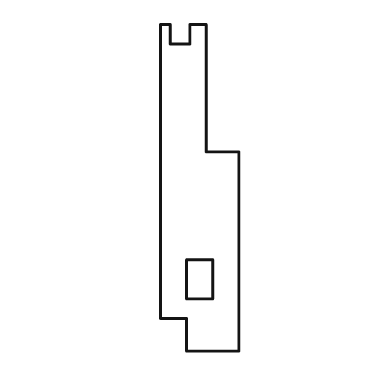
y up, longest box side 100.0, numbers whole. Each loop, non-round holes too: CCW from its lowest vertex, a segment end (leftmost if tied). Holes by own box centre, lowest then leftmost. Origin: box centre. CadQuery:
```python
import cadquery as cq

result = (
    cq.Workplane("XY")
    .moveTo(-4.0, -50.0)
    .lineTo(12.0, -50.0)
    .lineTo(12.0, 11.0)
    .lineTo(2.0, 11.0)
    .lineTo(2.0, 50.0)
    .lineTo(-3.0, 50.0)
    .lineTo(-3.0, 44.0)
    .lineTo(-9.0, 44.0)
    .lineTo(-9.0, 50.0)
    .lineTo(-12.0, 50.0)
    .lineTo(-12.0, -40.0)
    .lineTo(-4.0, -40.0)
    .close()
    .moveTo(-4.0, -34.0)
    .lineTo(4.0, -34.0)
    .lineTo(4.0, -22.0)
    .lineTo(-4.0, -22.0)
    .close()
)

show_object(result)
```